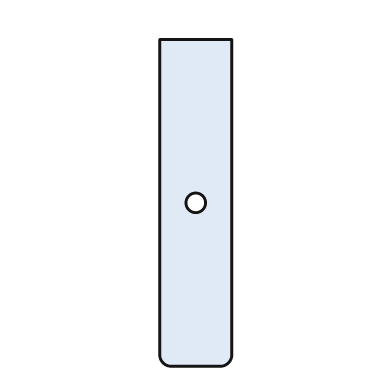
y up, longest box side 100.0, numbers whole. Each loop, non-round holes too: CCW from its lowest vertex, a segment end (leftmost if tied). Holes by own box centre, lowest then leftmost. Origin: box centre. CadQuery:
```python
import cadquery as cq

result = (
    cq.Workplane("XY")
    .moveTo(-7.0, -50.0)
    .lineTo(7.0, -50.0)
    .threePointArc((10.0, -49.0), (11.0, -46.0))
    .lineTo(11.0, 50.0)
    .lineTo(-11.0, 50.0)
    .lineTo(-11.0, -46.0)
    .threePointArc((-10.0, -49.0), (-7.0, -50.0))
    .close()
    .moveTo(0.0, 0.0)
    .circle(3.0)
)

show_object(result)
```